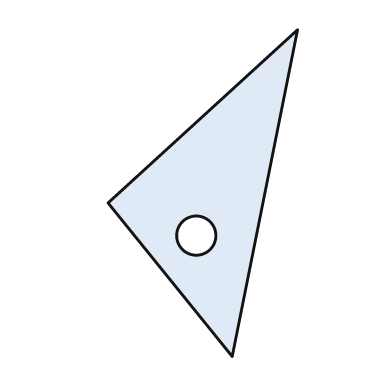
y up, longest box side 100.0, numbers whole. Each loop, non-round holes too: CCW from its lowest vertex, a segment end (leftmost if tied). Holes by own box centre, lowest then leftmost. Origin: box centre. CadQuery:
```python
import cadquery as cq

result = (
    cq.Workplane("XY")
    .moveTo(9.0, -50.0)
    .lineTo(29.0, 50.0)
    .lineTo(-29.0, -3.0)
    .close()
    .moveTo(-2.0, -13.0)
    .circle(6.0)
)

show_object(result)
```